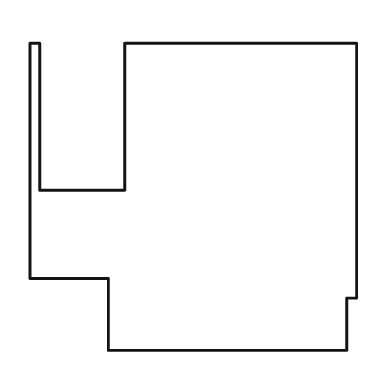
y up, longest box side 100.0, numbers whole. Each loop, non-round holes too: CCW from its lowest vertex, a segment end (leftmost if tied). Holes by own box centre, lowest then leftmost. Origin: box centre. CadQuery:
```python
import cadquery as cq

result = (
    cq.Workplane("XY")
    .moveTo(-26.0, -47.0)
    .lineTo(47.0, -47.0)
    .lineTo(47.0, -31.0)
    .lineTo(50.0, -31.0)
    .lineTo(50.0, 47.0)
    .lineTo(-21.0, 47.0)
    .lineTo(-21.0, 2.0)
    .lineTo(-47.0, 2.0)
    .lineTo(-47.0, 47.0)
    .lineTo(-50.0, 47.0)
    .lineTo(-50.0, -25.0)
    .lineTo(-26.0, -25.0)
    .close()
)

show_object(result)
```